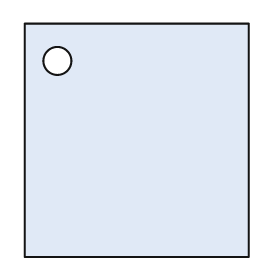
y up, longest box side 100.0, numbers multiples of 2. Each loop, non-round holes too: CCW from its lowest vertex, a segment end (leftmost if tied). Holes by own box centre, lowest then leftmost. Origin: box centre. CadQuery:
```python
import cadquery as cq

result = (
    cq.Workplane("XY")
    .moveTo(-48.0, -50.0)
    .lineTo(48.0, -50.0)
    .lineTo(48.0, 50.0)
    .lineTo(-48.0, 50.0)
    .close()
    .moveTo(-34.0, 34.0)
    .circle(6.0)
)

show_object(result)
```